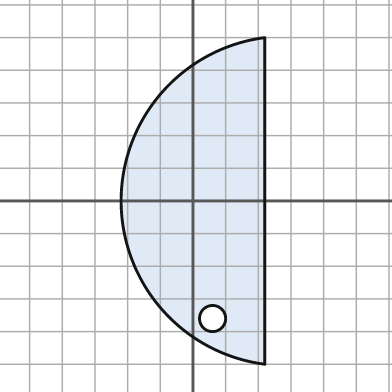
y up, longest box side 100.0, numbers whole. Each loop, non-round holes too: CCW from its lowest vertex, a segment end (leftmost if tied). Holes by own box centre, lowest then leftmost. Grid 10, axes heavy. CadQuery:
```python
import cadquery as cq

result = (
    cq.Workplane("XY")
    .moveTo(22.0, -50.0)
    .lineTo(22.0, 50.0)
    .threePointArc((-22.0, 0.0), (22.0, -50.0))
    .close()
    .moveTo(6.0, -36.0)
    .circle(4.0)
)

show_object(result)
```